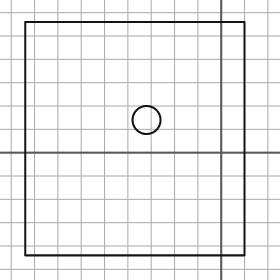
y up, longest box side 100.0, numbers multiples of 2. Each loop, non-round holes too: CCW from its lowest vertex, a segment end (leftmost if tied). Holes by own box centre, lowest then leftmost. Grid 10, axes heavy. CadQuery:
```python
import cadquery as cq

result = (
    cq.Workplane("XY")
    .moveTo(-84.0, -44.0)
    .lineTo(10.0, -44.0)
    .lineTo(10.0, 56.0)
    .lineTo(-84.0, 56.0)
    .close()
    .moveTo(-32.0, 14.0)
    .circle(6.0)
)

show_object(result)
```